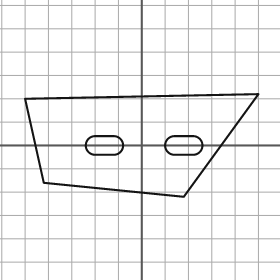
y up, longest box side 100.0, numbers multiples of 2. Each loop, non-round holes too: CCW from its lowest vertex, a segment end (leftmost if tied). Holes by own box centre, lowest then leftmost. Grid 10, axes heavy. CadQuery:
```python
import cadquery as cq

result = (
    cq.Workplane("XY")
    .moveTo(18.0, -22.0)
    .lineTo(50.0, 22.0)
    .lineTo(-50.0, 20.0)
    .lineTo(-42.0, -16.0)
    .close()
    .moveTo(-20.0, -4.0)
    .lineTo(-12.0, -4.0)
    .threePointArc((-8.0, 0.0), (-12.0, 4.0))
    .lineTo(-20.0, 4.0)
    .threePointArc((-24.0, 0.0), (-20.0, -4.0))
    .close()
    .moveTo(14.0, -4.0)
    .lineTo(22.0, -4.0)
    .threePointArc((26.0, 0.0), (22.0, 4.0))
    .lineTo(14.0, 4.0)
    .threePointArc((10.0, 0.0), (14.0, -4.0))
    .close()
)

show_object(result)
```